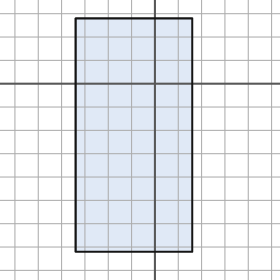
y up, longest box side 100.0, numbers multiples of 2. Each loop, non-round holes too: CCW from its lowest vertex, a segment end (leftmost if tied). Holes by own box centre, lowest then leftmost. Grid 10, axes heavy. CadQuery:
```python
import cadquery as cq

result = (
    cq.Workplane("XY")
    .moveTo(-34.0, -72.0)
    .lineTo(16.0, -72.0)
    .lineTo(16.0, 28.0)
    .lineTo(-34.0, 28.0)
    .close()
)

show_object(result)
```